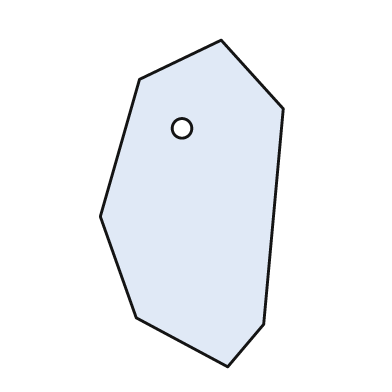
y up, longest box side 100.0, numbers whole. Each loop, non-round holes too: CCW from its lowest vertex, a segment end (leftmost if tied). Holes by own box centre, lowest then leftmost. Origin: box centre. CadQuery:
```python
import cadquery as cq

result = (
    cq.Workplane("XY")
    .moveTo(11.0, -50.0)
    .lineTo(22.0, -37.0)
    .lineTo(28.0, 29.0)
    .lineTo(9.0, 50.0)
    .lineTo(-16.0, 38.0)
    .lineTo(-28.0, -4.0)
    .lineTo(-17.0, -35.0)
    .close()
    .moveTo(-3.0, 23.0)
    .circle(3.0)
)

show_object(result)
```